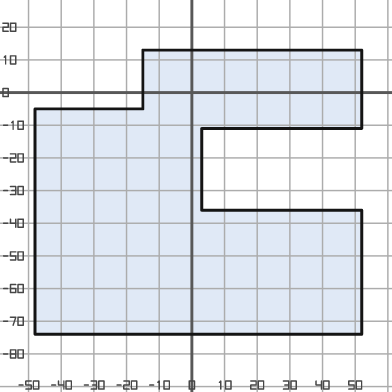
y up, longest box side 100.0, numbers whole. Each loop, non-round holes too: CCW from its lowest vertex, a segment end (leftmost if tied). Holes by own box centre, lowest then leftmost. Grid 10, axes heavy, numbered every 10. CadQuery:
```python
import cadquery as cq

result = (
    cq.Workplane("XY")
    .moveTo(-48.0, -74.0)
    .lineTo(52.0, -74.0)
    .lineTo(52.0, -36.0)
    .lineTo(3.0, -36.0)
    .lineTo(3.0, -11.0)
    .lineTo(52.0, -11.0)
    .lineTo(52.0, 13.0)
    .lineTo(-15.0, 13.0)
    .lineTo(-15.0, -5.0)
    .lineTo(-48.0, -5.0)
    .close()
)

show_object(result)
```